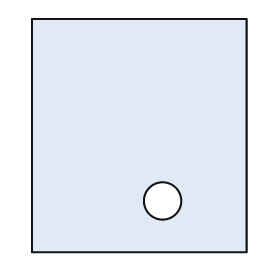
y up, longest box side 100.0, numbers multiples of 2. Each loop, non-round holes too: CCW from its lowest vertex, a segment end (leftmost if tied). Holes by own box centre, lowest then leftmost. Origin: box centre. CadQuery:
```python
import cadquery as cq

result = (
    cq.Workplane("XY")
    .moveTo(-46.0, -50.0)
    .lineTo(46.0, -50.0)
    .lineTo(46.0, 50.0)
    .lineTo(-46.0, 50.0)
    .close()
    .moveTo(10.0, -28.0)
    .circle(8.0)
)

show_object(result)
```